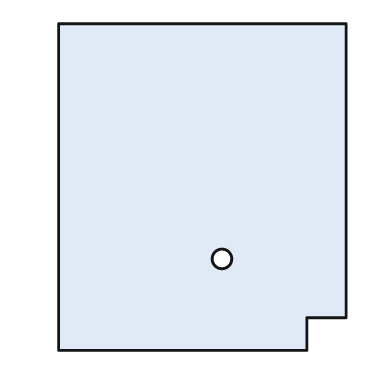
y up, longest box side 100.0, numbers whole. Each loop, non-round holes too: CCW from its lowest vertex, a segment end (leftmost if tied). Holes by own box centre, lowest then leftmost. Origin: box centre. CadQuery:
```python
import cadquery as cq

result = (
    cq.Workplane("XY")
    .moveTo(-44.0, -50.0)
    .lineTo(32.0, -50.0)
    .lineTo(32.0, -40.0)
    .lineTo(44.0, -40.0)
    .lineTo(44.0, 50.0)
    .lineTo(-44.0, 50.0)
    .close()
    .moveTo(6.0, -22.0)
    .circle(3.0)
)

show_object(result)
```